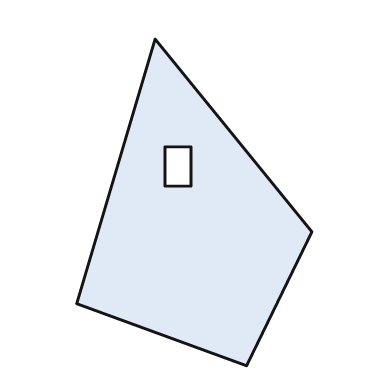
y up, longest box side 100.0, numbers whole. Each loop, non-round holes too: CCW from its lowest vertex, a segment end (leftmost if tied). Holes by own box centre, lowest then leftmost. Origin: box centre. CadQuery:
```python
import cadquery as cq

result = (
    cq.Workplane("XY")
    .moveTo(16.0, -50.0)
    .lineTo(36.0, -9.0)
    .lineTo(-12.0, 50.0)
    .lineTo(-36.0, -31.0)
    .close()
    .moveTo(-9.0, 5.0)
    .lineTo(-1.0, 5.0)
    .lineTo(-1.0, 17.0)
    .lineTo(-9.0, 17.0)
    .close()
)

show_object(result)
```